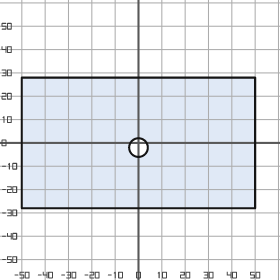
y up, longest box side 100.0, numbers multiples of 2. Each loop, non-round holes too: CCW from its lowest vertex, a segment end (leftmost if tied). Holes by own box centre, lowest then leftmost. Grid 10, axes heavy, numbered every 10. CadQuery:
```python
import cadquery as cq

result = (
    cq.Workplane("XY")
    .moveTo(-50.0, -28.0)
    .lineTo(50.0, -28.0)
    .lineTo(50.0, 28.0)
    .lineTo(-50.0, 28.0)
    .close()
    .moveTo(0.0, -2.0)
    .circle(4.0)
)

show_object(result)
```